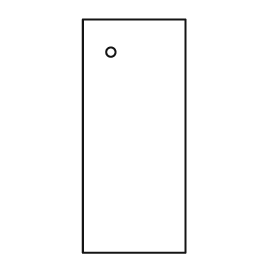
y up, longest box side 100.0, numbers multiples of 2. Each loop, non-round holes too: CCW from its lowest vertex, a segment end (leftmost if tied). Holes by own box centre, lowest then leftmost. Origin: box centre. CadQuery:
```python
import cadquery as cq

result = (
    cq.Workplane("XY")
    .moveTo(-22.0, -50.0)
    .lineTo(22.0, -50.0)
    .lineTo(22.0, 50.0)
    .lineTo(-22.0, 50.0)
    .close()
    .moveTo(-10.0, 36.0)
    .circle(2.0)
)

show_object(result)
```